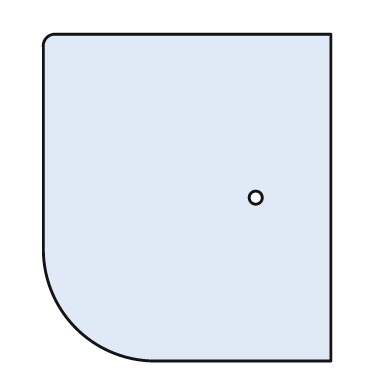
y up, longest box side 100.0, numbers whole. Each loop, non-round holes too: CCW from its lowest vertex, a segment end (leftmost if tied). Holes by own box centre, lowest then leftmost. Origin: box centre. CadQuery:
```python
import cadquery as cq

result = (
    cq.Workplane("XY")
    .moveTo(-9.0, -50.0)
    .lineTo(44.0, -50.0)
    .lineTo(44.0, 50.0)
    .lineTo(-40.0, 50.0)
    .threePointArc((-43.0, 49.0), (-44.0, 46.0))
    .lineTo(-44.0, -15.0)
    .threePointArc((-34.0, -40.0), (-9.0, -50.0))
    .close()
    .moveTo(21.0, 0.0)
    .circle(2.0)
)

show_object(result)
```